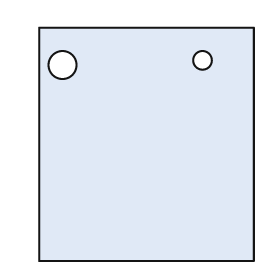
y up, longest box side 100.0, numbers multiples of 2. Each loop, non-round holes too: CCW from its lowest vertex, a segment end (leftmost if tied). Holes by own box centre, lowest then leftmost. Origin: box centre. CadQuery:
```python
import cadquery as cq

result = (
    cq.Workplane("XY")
    .moveTo(-46.0, -50.0)
    .lineTo(46.0, -50.0)
    .lineTo(46.0, 50.0)
    .lineTo(-46.0, 50.0)
    .close()
    .moveTo(-36.0, 34.0)
    .circle(6.0)
    .moveTo(24.0, 36.0)
    .circle(4.0)
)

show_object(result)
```